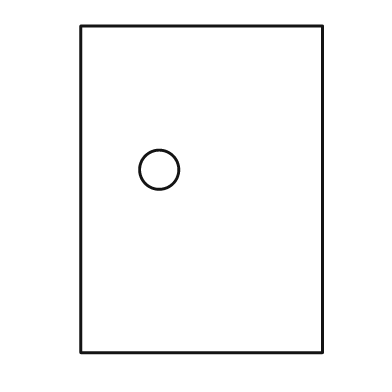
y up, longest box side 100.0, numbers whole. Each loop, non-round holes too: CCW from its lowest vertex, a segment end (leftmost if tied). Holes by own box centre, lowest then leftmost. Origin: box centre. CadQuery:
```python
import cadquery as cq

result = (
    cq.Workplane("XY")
    .moveTo(-37.0, -50.0)
    .lineTo(37.0, -50.0)
    .lineTo(37.0, 50.0)
    .lineTo(-37.0, 50.0)
    .close()
    .moveTo(-13.0, 6.0)
    .circle(6.0)
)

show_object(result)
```